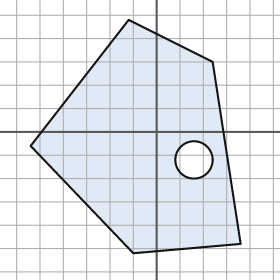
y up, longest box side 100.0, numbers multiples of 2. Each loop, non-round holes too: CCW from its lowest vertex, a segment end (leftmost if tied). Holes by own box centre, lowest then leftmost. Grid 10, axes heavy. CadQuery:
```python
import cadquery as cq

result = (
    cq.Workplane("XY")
    .moveTo(-10.0, -52.0)
    .lineTo(36.0, -48.0)
    .lineTo(24.0, 30.0)
    .lineTo(-12.0, 48.0)
    .lineTo(-54.0, -6.0)
    .close()
    .moveTo(16.0, -12.0)
    .circle(8.0)
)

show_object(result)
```